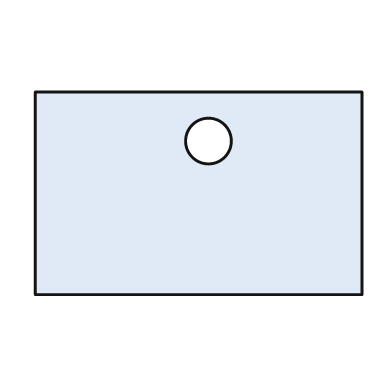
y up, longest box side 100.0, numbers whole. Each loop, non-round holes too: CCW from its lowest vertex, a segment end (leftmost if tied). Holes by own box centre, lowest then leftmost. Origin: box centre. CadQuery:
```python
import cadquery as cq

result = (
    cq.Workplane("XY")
    .moveTo(-50.0, -31.0)
    .lineTo(50.0, -31.0)
    .lineTo(50.0, 31.0)
    .lineTo(-50.0, 31.0)
    .close()
    .moveTo(3.0, 16.0)
    .circle(7.0)
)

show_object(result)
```